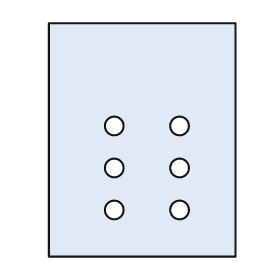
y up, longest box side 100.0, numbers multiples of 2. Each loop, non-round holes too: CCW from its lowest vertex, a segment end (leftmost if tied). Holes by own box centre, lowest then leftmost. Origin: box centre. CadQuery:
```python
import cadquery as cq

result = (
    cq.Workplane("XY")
    .moveTo(-40.0, -50.0)
    .lineTo(40.0, -50.0)
    .lineTo(40.0, 50.0)
    .lineTo(-40.0, 50.0)
    .close()
    .moveTo(-12.0, -30.0)
    .circle(4.0)
    .moveTo(16.0, -30.0)
    .circle(4.0)
    .moveTo(-12.0, -12.0)
    .circle(4.0)
    .moveTo(16.0, -12.0)
    .circle(4.0)
    .moveTo(-12.0, 6.0)
    .circle(4.0)
    .moveTo(16.0, 6.0)
    .circle(4.0)
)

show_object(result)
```